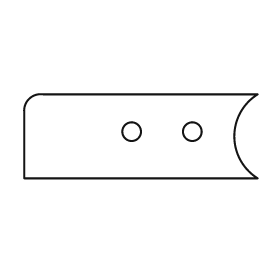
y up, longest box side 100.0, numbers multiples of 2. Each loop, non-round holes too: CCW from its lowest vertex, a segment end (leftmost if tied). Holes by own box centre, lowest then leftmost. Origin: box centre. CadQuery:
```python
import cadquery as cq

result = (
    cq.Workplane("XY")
    .moveTo(-50.0, -18.0)
    .lineTo(50.0, -18.0)
    .threePointArc((40.0, 0.0), (50.0, 18.0))
    .lineTo(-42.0, 18.0)
    .threePointArc((-48.0, 16.0), (-50.0, 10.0))
    .close()
    .moveTo(-4.0, 2.0)
    .circle(4.0)
    .moveTo(22.0, 2.0)
    .circle(4.0)
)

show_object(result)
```